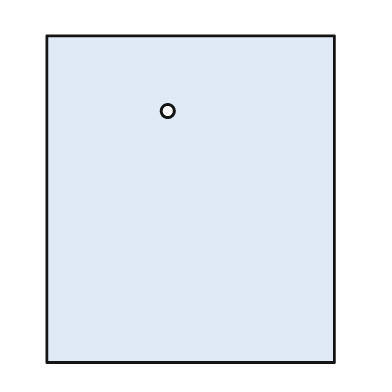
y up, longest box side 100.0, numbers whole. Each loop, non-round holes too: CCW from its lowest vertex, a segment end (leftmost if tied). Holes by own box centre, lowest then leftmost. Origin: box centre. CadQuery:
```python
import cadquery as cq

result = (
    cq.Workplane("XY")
    .moveTo(-44.0, -50.0)
    .lineTo(44.0, -50.0)
    .lineTo(44.0, 50.0)
    .lineTo(-44.0, 50.0)
    .close()
    .moveTo(-7.0, 27.0)
    .circle(2.0)
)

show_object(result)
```